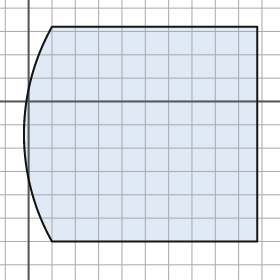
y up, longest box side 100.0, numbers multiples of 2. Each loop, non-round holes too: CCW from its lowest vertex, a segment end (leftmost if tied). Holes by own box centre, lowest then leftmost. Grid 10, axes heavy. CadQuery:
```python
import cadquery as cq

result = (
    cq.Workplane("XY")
    .moveTo(10.0, -60.0)
    .lineTo(98.0, -60.0)
    .lineTo(98.0, 32.0)
    .lineTo(10.0, 32.0)
    .threePointArc((-2.0, -14.0), (10.0, -60.0))
    .close()
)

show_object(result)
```